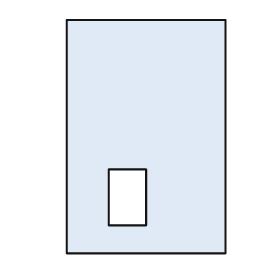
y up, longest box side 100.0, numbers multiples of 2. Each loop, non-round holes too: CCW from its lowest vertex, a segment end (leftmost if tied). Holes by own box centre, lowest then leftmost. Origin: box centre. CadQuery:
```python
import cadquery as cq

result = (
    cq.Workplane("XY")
    .moveTo(-34.0, -50.0)
    .lineTo(34.0, -50.0)
    .lineTo(34.0, 50.0)
    .lineTo(-34.0, 50.0)
    .close()
    .moveTo(-16.0, -38.0)
    .lineTo(0.0, -38.0)
    .lineTo(0.0, -14.0)
    .lineTo(-16.0, -14.0)
    .close()
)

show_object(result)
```